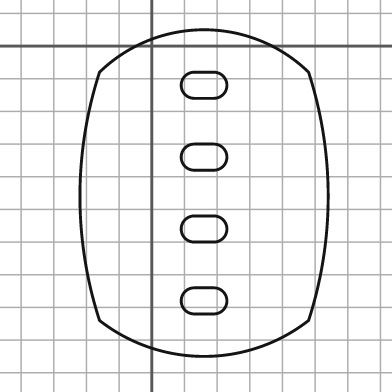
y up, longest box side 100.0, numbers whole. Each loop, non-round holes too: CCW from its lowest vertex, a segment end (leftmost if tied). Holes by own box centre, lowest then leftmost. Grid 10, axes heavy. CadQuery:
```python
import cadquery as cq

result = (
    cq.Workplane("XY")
    .moveTo(-16.0, -84.0)
    .threePointArc((16.0, -95.0), (48.0, -84.0))
    .threePointArc((54.0, -46.0), (48.0, -8.0))
    .threePointArc((16.0, 5.0), (-16.0, -8.0))
    .threePointArc((-22.0, -46.0), (-16.0, -84.0))
    .close()
    .moveTo(13.0, -82.0)
    .lineTo(19.0, -82.0)
    .threePointArc((23.0, -78.0), (19.0, -74.0))
    .lineTo(13.0, -74.0)
    .threePointArc((9.0, -78.0), (13.0, -82.0))
    .close()
    .moveTo(13.0, -60.0)
    .lineTo(19.0, -60.0)
    .threePointArc((23.0, -56.0), (19.0, -52.0))
    .lineTo(13.0, -52.0)
    .threePointArc((9.0, -56.0), (13.0, -60.0))
    .close()
    .moveTo(13.0, -38.0)
    .lineTo(19.0, -38.0)
    .threePointArc((23.0, -34.0), (19.0, -30.0))
    .lineTo(13.0, -30.0)
    .threePointArc((9.0, -34.0), (13.0, -38.0))
    .close()
    .moveTo(13.0, -16.0)
    .lineTo(19.0, -16.0)
    .threePointArc((23.0, -12.0), (19.0, -8.0))
    .lineTo(13.0, -8.0)
    .threePointArc((9.0, -12.0), (13.0, -16.0))
    .close()
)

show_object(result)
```